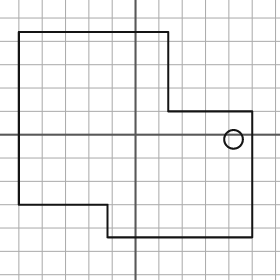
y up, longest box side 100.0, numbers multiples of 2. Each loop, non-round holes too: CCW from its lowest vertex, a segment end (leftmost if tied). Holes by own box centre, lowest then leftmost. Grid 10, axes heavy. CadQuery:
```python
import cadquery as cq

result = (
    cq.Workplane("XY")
    .moveTo(-12.0, -44.0)
    .lineTo(50.0, -44.0)
    .lineTo(50.0, 10.0)
    .lineTo(14.0, 10.0)
    .lineTo(14.0, 44.0)
    .lineTo(-50.0, 44.0)
    .lineTo(-50.0, -30.0)
    .lineTo(-12.0, -30.0)
    .close()
    .moveTo(42.0, -2.0)
    .circle(4.0)
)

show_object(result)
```